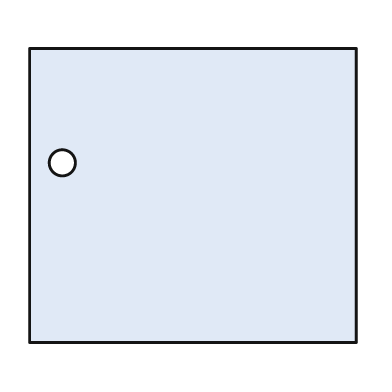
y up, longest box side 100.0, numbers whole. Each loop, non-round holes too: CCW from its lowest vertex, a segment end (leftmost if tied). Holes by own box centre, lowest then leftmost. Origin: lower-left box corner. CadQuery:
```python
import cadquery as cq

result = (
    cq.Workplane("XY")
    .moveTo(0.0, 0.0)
    .lineTo(100.0, 0.0)
    .lineTo(100.0, 90.0)
    .lineTo(0.0, 90.0)
    .close()
    .moveTo(10.0, 55.0)
    .circle(4.0)
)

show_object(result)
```